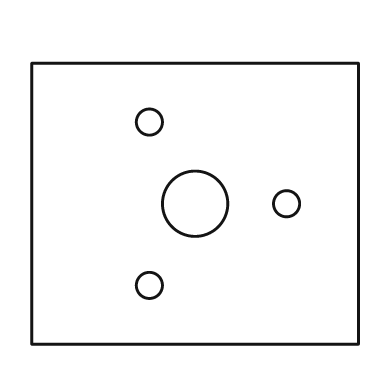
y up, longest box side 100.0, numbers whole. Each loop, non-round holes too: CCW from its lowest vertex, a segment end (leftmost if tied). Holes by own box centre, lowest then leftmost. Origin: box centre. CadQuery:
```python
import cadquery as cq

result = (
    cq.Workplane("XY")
    .moveTo(-50.0, -43.0)
    .lineTo(50.0, -43.0)
    .lineTo(50.0, 43.0)
    .lineTo(-50.0, 43.0)
    .close()
    .moveTo(-14.0, -25.0)
    .circle(4.0)
    .moveTo(0.0, 0.0)
    .circle(10.0)
    .moveTo(28.0, 0.0)
    .circle(4.0)
    .moveTo(-14.0, 25.0)
    .circle(4.0)
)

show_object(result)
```